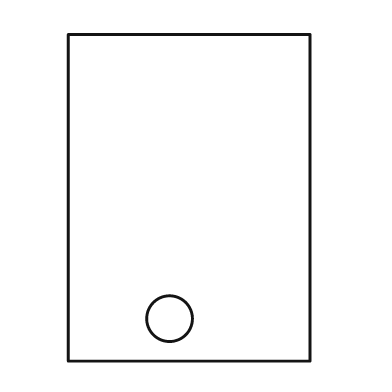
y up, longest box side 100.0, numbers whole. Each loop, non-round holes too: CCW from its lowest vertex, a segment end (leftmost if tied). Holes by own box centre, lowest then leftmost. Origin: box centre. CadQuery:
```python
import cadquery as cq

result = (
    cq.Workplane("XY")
    .moveTo(-37.0, -50.0)
    .lineTo(37.0, -50.0)
    .lineTo(37.0, 50.0)
    .lineTo(-37.0, 50.0)
    .close()
    .moveTo(-6.0, -37.0)
    .circle(7.0)
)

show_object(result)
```